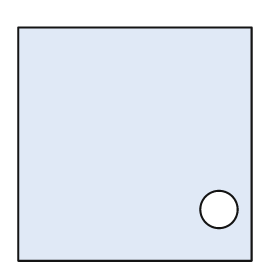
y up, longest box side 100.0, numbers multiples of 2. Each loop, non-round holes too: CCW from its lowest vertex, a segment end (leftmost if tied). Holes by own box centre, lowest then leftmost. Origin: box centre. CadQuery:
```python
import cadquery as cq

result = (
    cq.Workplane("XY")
    .moveTo(-50.0, -50.0)
    .lineTo(50.0, -50.0)
    .lineTo(50.0, 50.0)
    .lineTo(-50.0, 50.0)
    .close()
    .moveTo(36.0, -28.0)
    .circle(8.0)
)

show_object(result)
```